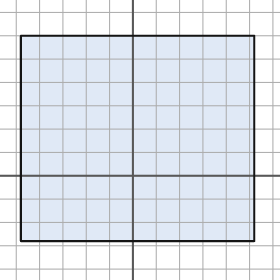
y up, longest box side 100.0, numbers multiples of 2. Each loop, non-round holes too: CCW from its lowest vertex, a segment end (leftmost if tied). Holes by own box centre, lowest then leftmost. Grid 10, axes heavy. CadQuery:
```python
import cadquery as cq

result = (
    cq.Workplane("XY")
    .moveTo(-48.0, -28.0)
    .lineTo(52.0, -28.0)
    .lineTo(52.0, 60.0)
    .lineTo(-48.0, 60.0)
    .close()
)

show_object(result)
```